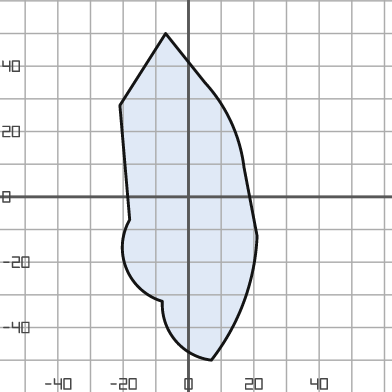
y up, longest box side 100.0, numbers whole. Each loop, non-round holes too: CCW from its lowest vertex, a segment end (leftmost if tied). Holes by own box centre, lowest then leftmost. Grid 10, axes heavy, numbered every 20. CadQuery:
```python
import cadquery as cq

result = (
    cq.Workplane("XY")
    .moveTo(7.0, -50.0)
    .threePointArc((17.0, -32.0), (21.0, -12.0))
    .lineTo(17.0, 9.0)
    .threePointArc((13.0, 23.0), (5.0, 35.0))
    .lineTo(-7.0, 50.0)
    .lineTo(-21.0, 28.0)
    .lineTo(-18.0, -7.0)
    .threePointArc((-19.0, -22.0), (-8.0, -32.0))
    .threePointArc((-4.0, -44.0), (7.0, -50.0))
    .close()
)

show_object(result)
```